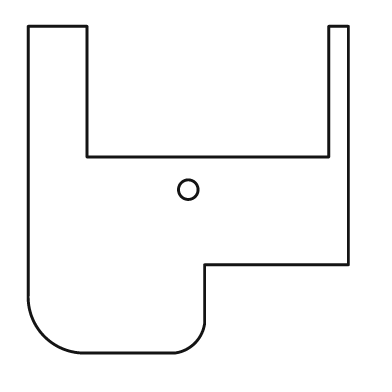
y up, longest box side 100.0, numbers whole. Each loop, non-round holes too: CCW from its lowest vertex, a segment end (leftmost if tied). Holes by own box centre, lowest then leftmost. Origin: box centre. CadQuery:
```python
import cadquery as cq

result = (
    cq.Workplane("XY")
    .moveTo(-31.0, -50.0)
    .lineTo(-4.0, -50.0)
    .threePointArc((2.0, -47.0), (5.0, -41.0))
    .lineTo(5.0, -23.0)
    .lineTo(49.0, -23.0)
    .lineTo(49.0, 50.0)
    .lineTo(43.0, 50.0)
    .lineTo(43.0, 10.0)
    .lineTo(-31.0, 10.0)
    .lineTo(-31.0, 50.0)
    .lineTo(-49.0, 50.0)
    .lineTo(-49.0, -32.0)
    .threePointArc((-44.0, -45.0), (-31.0, -50.0))
    .close()
    .moveTo(0.0, 0.0)
    .circle(3.0)
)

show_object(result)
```